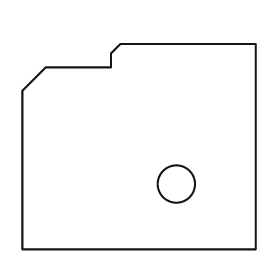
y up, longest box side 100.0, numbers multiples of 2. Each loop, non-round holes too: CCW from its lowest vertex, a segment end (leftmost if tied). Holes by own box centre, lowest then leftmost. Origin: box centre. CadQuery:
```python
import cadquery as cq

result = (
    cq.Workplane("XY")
    .moveTo(-50.0, -44.0)
    .lineTo(50.0, -44.0)
    .lineTo(50.0, 44.0)
    .lineTo(-8.0, 44.0)
    .lineTo(-12.0, 40.0)
    .lineTo(-12.0, 34.0)
    .lineTo(-40.0, 34.0)
    .lineTo(-50.0, 24.0)
    .close()
    .moveTo(16.0, -16.0)
    .circle(8.0)
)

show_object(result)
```